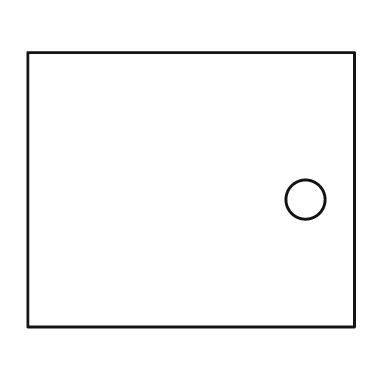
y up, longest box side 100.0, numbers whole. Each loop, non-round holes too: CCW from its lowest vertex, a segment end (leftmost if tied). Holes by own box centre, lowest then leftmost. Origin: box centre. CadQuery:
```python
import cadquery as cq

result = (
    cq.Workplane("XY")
    .moveTo(-50.0, -42.0)
    .lineTo(50.0, -42.0)
    .lineTo(50.0, 42.0)
    .lineTo(-50.0, 42.0)
    .close()
    .moveTo(35.0, -3.0)
    .circle(6.0)
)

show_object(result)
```